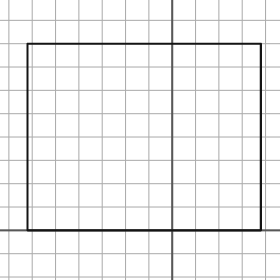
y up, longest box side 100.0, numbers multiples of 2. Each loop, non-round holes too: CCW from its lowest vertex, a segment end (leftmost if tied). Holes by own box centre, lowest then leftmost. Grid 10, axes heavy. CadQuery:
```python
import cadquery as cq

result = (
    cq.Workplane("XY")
    .moveTo(-62.0, 0.0)
    .lineTo(38.0, 0.0)
    .lineTo(38.0, 80.0)
    .lineTo(-62.0, 80.0)
    .close()
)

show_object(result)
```